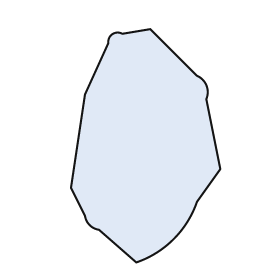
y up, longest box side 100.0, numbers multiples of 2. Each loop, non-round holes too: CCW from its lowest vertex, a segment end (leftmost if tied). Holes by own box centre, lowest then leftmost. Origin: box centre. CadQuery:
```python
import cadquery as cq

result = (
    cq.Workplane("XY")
    .moveTo(-4.0, -50.0)
    .threePointArc((12.0, -40.0), (22.0, -24.0))
    .lineTo(32.0, -10.0)
    .lineTo(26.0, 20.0)
    .threePointArc((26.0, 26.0), (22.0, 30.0))
    .lineTo(2.0, 50.0)
    .lineTo(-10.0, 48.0)
    .threePointArc((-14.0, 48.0), (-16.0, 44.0))
    .lineTo(-26.0, 22.0)
    .lineTo(-32.0, -18.0)
    .lineTo(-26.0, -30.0)
    .threePointArc((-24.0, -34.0), (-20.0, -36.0))
    .close()
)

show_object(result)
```